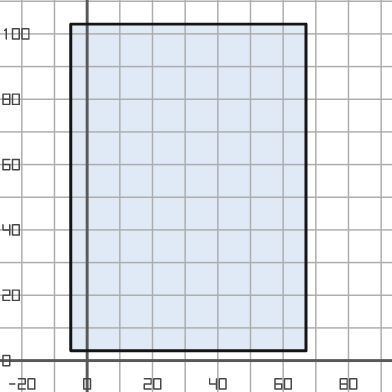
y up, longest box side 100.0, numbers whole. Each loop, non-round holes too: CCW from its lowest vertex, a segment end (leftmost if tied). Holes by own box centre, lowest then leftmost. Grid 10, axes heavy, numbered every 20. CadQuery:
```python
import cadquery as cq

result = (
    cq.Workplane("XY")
    .moveTo(-5.0, 3.0)
    .lineTo(67.0, 3.0)
    .lineTo(67.0, 103.0)
    .lineTo(-5.0, 103.0)
    .close()
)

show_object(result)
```